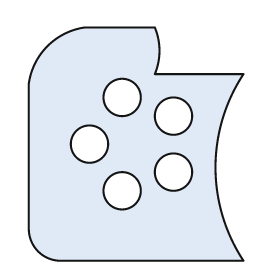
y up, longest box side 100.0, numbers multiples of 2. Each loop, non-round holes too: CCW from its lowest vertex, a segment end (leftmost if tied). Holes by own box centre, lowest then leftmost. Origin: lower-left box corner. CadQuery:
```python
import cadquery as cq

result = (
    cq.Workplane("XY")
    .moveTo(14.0, 0.0)
    .lineTo(92.0, 0.0)
    .threePointArc((80.0, 40.0), (92.0, 80.0))
    .lineTo(54.0, 80.0)
    .threePointArc((56.0, 90.0), (54.0, 100.0))
    .lineTo(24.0, 100.0)
    .threePointArc((8.0, 92.0), (0.0, 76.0))
    .lineTo(0.0, 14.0)
    .threePointArc((4.0, 4.0), (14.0, 0.0))
    .close()
    .moveTo(40.0, 30.0)
    .circle(8.0)
    .moveTo(62.0, 38.0)
    .circle(8.0)
    .moveTo(26.0, 50.0)
    .circle(8.0)
    .moveTo(62.0, 62.0)
    .circle(8.0)
    .moveTo(40.0, 70.0)
    .circle(8.0)
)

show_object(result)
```